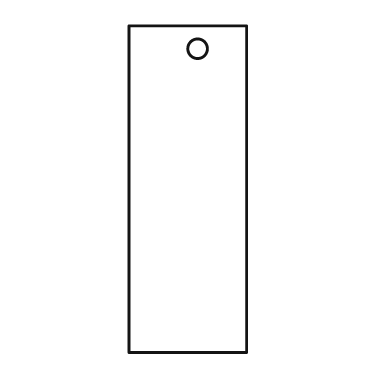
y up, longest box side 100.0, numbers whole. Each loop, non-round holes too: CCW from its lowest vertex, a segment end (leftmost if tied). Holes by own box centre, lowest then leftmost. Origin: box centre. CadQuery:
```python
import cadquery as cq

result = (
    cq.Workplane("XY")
    .moveTo(-18.0, -50.0)
    .lineTo(18.0, -50.0)
    .lineTo(18.0, 50.0)
    .lineTo(-18.0, 50.0)
    .close()
    .moveTo(3.0, 43.0)
    .circle(3.0)
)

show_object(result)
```